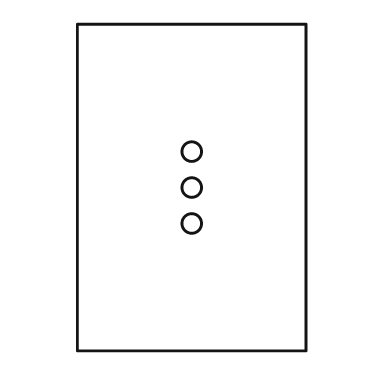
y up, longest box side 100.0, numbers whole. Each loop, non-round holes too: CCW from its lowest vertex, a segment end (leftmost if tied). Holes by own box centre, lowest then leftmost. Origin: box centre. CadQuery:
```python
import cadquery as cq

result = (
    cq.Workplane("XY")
    .moveTo(-35.0, -50.0)
    .lineTo(35.0, -50.0)
    .lineTo(35.0, 50.0)
    .lineTo(-35.0, 50.0)
    .close()
    .moveTo(0.0, -11.0)
    .circle(3.0)
    .moveTo(0.0, 0.0)
    .circle(3.0)
    .moveTo(0.0, 11.0)
    .circle(3.0)
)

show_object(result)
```